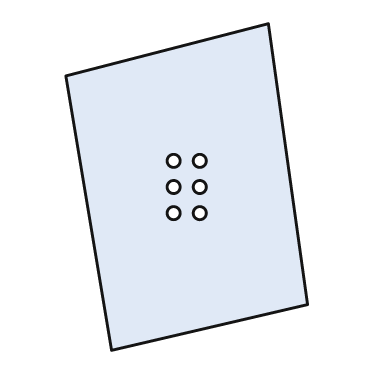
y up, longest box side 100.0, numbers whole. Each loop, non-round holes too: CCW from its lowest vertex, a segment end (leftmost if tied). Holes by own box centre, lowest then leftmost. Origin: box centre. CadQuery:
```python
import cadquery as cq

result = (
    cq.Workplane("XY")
    .moveTo(-23.0, -50.0)
    .lineTo(37.0, -36.0)
    .lineTo(25.0, 50.0)
    .lineTo(-37.0, 34.0)
    .close()
    .moveTo(-4.0, -8.0)
    .circle(2.0)
    .moveTo(4.0, -8.0)
    .circle(2.0)
    .moveTo(-4.0, 0.0)
    .circle(2.0)
    .moveTo(4.0, 0.0)
    .circle(2.0)
    .moveTo(-4.0, 8.0)
    .circle(2.0)
    .moveTo(4.0, 8.0)
    .circle(2.0)
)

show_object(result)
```